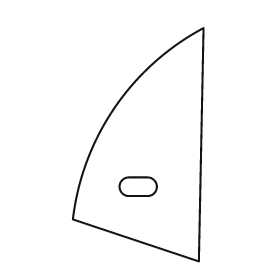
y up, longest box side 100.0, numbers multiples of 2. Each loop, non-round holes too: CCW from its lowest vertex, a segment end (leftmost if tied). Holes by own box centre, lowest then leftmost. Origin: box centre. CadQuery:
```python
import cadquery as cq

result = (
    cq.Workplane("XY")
    .moveTo(26.0, -50.0)
    .lineTo(28.0, 50.0)
    .threePointArc((-10.0, 16.0), (-28.0, -32.0))
    .close()
    .moveTo(-4.0, -22.0)
    .lineTo(4.0, -22.0)
    .threePointArc((8.0, -18.0), (4.0, -14.0))
    .lineTo(-4.0, -14.0)
    .threePointArc((-8.0, -18.0), (-4.0, -22.0))
    .close()
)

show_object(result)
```